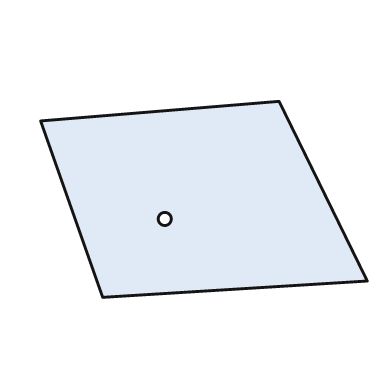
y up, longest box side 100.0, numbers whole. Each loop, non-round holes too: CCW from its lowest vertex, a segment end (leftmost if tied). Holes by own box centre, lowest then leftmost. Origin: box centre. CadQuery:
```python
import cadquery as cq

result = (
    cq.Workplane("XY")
    .moveTo(-31.0, -30.0)
    .lineTo(50.0, -25.0)
    .lineTo(23.0, 30.0)
    .lineTo(-50.0, 24.0)
    .close()
    .moveTo(-12.0, -6.0)
    .circle(2.0)
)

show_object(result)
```